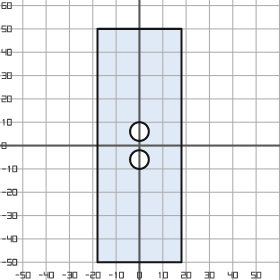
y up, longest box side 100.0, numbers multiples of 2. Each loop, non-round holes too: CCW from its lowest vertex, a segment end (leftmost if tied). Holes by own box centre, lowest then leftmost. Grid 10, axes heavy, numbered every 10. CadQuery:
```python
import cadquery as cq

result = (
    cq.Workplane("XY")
    .moveTo(-18.0, -50.0)
    .lineTo(18.0, -50.0)
    .lineTo(18.0, 50.0)
    .lineTo(-18.0, 50.0)
    .close()
    .moveTo(0.0, -6.0)
    .circle(4.0)
    .moveTo(0.0, 6.0)
    .circle(4.0)
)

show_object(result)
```